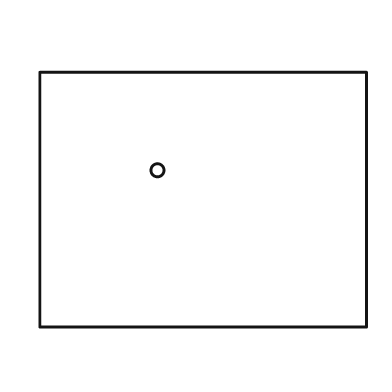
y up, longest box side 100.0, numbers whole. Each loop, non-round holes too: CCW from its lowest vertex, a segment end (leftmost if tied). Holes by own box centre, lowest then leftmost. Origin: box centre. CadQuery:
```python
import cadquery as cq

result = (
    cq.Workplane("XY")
    .moveTo(-50.0, -39.0)
    .lineTo(50.0, -39.0)
    .lineTo(50.0, 39.0)
    .lineTo(-50.0, 39.0)
    .close()
    .moveTo(-14.0, 9.0)
    .circle(2.0)
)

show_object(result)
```